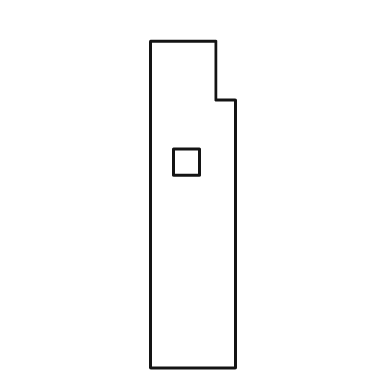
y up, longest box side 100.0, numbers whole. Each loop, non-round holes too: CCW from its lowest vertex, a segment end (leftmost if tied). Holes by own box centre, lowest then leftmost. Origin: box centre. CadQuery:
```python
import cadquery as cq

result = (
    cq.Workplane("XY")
    .moveTo(-13.0, -50.0)
    .lineTo(13.0, -50.0)
    .lineTo(13.0, 32.0)
    .lineTo(7.0, 32.0)
    .lineTo(7.0, 50.0)
    .lineTo(-13.0, 50.0)
    .close()
    .moveTo(-6.0, 9.0)
    .lineTo(2.0, 9.0)
    .lineTo(2.0, 17.0)
    .lineTo(-6.0, 17.0)
    .close()
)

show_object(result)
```